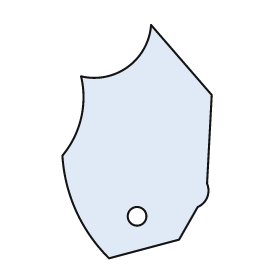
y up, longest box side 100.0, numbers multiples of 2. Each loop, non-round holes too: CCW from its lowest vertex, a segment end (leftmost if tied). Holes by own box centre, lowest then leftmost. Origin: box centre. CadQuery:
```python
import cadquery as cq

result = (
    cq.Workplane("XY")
    .moveTo(-12.0, -50.0)
    .lineTo(18.0, -42.0)
    .lineTo(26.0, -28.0)
    .threePointArc((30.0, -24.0), (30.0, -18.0))
    .lineTo(32.0, 20.0)
    .lineTo(6.0, 50.0)
    .threePointArc((-4.0, 32.0), (-24.0, 28.0))
    .threePointArc((-24.0, 10.0), (-32.0, -6.0))
    .threePointArc((-26.0, -30.0), (-12.0, -50.0))
    .close()
    .moveTo(0.0, -32.0)
    .circle(4.0)
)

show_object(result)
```